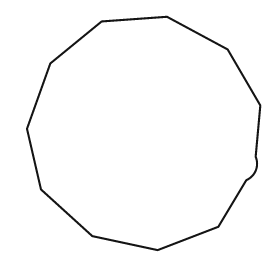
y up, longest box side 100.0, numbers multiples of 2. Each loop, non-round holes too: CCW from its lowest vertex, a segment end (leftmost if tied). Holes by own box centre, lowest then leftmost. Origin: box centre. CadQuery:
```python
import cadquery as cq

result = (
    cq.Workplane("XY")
    .moveTo(6.0, -50.0)
    .lineTo(32.0, -40.0)
    .lineTo(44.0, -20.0)
    .threePointArc((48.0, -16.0), (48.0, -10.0))
    .lineTo(50.0, 12.0)
    .lineTo(36.0, 36.0)
    .lineTo(10.0, 50.0)
    .lineTo(-18.0, 48.0)
    .lineTo(-40.0, 30.0)
    .lineTo(-50.0, 2.0)
    .lineTo(-44.0, -24.0)
    .lineTo(-22.0, -44.0)
    .close()
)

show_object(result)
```